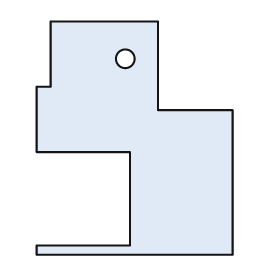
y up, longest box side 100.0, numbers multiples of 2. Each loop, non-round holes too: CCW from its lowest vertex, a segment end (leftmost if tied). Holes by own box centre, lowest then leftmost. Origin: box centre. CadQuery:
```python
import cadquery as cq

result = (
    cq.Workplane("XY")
    .moveTo(-42.0, -50.0)
    .lineTo(42.0, -50.0)
    .lineTo(42.0, 12.0)
    .lineTo(10.0, 12.0)
    .lineTo(10.0, 50.0)
    .lineTo(-36.0, 50.0)
    .lineTo(-36.0, 22.0)
    .lineTo(-42.0, 22.0)
    .lineTo(-42.0, -6.0)
    .lineTo(-2.0, -6.0)
    .lineTo(-2.0, -46.0)
    .lineTo(-42.0, -46.0)
    .close()
    .moveTo(-4.0, 34.0)
    .circle(4.0)
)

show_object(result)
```